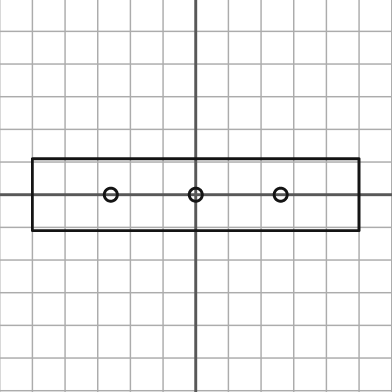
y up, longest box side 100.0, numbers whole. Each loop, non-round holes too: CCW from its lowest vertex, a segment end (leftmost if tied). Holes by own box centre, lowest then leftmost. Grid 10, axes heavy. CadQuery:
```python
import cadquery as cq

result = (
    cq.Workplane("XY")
    .moveTo(-50.0, -11.0)
    .lineTo(50.0, -11.0)
    .lineTo(50.0, 11.0)
    .lineTo(-50.0, 11.0)
    .close()
    .moveTo(-26.0, 0.0)
    .circle(2.0)
    .moveTo(0.0, 0.0)
    .circle(2.0)
    .moveTo(26.0, 0.0)
    .circle(2.0)
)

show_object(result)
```